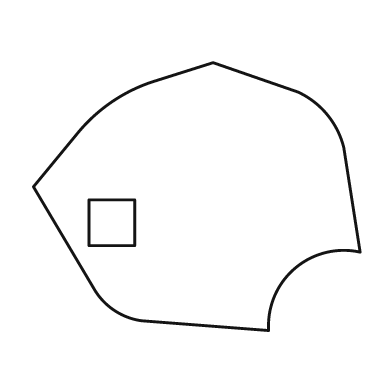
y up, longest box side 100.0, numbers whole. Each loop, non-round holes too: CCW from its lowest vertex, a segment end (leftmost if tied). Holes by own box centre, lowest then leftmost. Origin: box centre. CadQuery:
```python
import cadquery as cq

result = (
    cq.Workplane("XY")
    .moveTo(22.0, -41.0)
    .threePointArc((30.0, -22.0), (50.0, -17.0))
    .lineTo(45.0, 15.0)
    .threePointArc((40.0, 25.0), (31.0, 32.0))
    .lineTo(5.0, 41.0)
    .lineTo(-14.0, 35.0)
    .threePointArc((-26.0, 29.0), (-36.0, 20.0))
    .lineTo(-50.0, 3.0)
    .lineTo(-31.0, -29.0)
    .threePointArc((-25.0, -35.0), (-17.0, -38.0))
    .close()
    .moveTo(-33.0, -15.0)
    .lineTo(-19.0, -15.0)
    .lineTo(-19.0, -1.0)
    .lineTo(-33.0, -1.0)
    .close()
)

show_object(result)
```